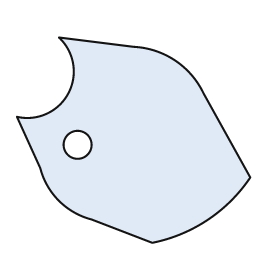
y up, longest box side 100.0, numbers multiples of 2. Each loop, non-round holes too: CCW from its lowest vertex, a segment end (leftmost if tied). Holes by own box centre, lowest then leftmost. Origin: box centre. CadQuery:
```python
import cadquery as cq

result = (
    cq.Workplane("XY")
    .moveTo(8.0, -44.0)
    .threePointArc((32.0, -34.0), (50.0, -16.0))
    .lineTo(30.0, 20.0)
    .threePointArc((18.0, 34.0), (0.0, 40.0))
    .lineTo(-32.0, 44.0)
    .threePointArc((-28.0, 20.0), (-50.0, 10.0))
    .lineTo(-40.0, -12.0)
    .threePointArc((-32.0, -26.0), (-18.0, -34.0))
    .close()
    .moveTo(-24.0, -2.0)
    .circle(6.0)
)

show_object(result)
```